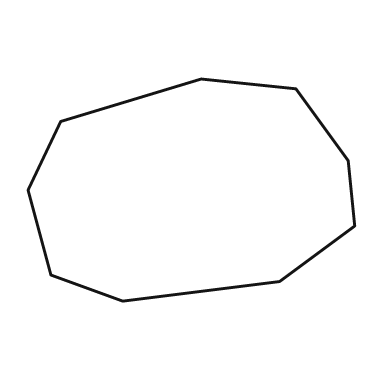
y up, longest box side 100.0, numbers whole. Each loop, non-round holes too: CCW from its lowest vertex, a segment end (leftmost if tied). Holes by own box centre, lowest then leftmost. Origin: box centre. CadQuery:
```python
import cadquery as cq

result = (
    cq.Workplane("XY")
    .moveTo(-21.0, -34.0)
    .lineTo(27.0, -28.0)
    .lineTo(50.0, -11.0)
    .lineTo(48.0, 9.0)
    .lineTo(32.0, 31.0)
    .lineTo(3.0, 34.0)
    .lineTo(-40.0, 21.0)
    .lineTo(-50.0, 0.0)
    .lineTo(-43.0, -26.0)
    .close()
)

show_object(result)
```